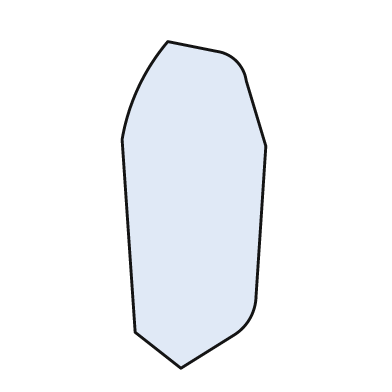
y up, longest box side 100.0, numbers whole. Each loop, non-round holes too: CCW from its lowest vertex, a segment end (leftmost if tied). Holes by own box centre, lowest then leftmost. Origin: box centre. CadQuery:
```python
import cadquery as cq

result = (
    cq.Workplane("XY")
    .moveTo(-4.0, -50.0)
    .lineTo(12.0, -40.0)
    .threePointArc((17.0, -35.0), (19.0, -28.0))
    .lineTo(22.0, 18.0)
    .lineTo(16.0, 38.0)
    .threePointArc((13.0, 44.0), (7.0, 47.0))
    .lineTo(-8.0, 50.0)
    .threePointArc((-17.0, 36.0), (-22.0, 20.0))
    .lineTo(-18.0, -39.0)
    .close()
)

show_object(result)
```